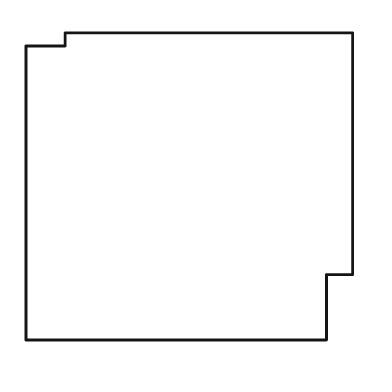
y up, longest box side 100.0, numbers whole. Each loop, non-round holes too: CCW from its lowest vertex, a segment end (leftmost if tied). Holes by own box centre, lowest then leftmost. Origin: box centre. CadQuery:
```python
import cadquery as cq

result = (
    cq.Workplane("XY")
    .moveTo(-50.0, -47.0)
    .lineTo(42.0, -47.0)
    .lineTo(42.0, -27.0)
    .lineTo(50.0, -27.0)
    .lineTo(50.0, 47.0)
    .lineTo(-38.0, 47.0)
    .lineTo(-38.0, 43.0)
    .lineTo(-50.0, 43.0)
    .close()
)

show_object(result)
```